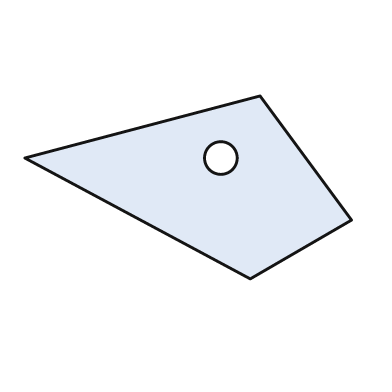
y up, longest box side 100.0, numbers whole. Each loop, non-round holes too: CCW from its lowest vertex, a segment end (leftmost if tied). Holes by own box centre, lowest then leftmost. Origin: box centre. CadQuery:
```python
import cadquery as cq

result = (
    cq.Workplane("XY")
    .moveTo(19.0, -28.0)
    .lineTo(50.0, -10.0)
    .lineTo(22.0, 28.0)
    .lineTo(-50.0, 9.0)
    .close()
    .moveTo(10.0, 9.0)
    .circle(5.0)
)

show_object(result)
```